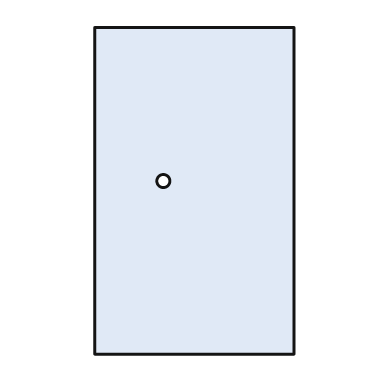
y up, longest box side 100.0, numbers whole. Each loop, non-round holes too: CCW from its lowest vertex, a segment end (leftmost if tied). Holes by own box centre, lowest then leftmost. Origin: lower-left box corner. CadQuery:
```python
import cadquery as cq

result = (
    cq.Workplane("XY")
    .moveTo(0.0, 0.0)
    .lineTo(61.0, 0.0)
    .lineTo(61.0, 100.0)
    .lineTo(0.0, 100.0)
    .close()
    .moveTo(21.0, 53.0)
    .circle(2.0)
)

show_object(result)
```